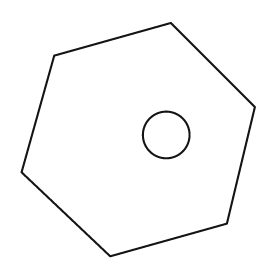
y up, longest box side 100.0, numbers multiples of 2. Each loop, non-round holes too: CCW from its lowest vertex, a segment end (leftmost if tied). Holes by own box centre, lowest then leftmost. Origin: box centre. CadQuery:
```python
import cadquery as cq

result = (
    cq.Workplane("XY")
    .moveTo(-12.0, -50.0)
    .lineTo(38.0, -36.0)
    .lineTo(50.0, 14.0)
    .lineTo(14.0, 50.0)
    .lineTo(-36.0, 36.0)
    .lineTo(-50.0, -14.0)
    .close()
    .moveTo(12.0, 2.0)
    .circle(10.0)
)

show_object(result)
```